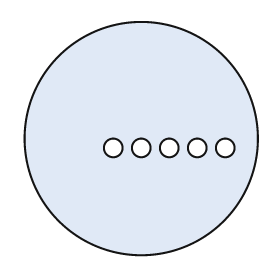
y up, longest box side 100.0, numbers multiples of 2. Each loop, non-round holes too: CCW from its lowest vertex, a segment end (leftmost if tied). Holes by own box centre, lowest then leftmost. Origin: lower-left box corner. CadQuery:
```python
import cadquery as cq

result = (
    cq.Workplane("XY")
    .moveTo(50.0, 50.0)
    .circle(50.0)
    .moveTo(38.0, 46.0)
    .circle(4.0)
    .moveTo(50.0, 46.0)
    .circle(4.0)
    .moveTo(62.0, 46.0)
    .circle(4.0)
    .moveTo(74.0, 46.0)
    .circle(4.0)
    .moveTo(86.0, 46.0)
    .circle(4.0)
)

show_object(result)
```